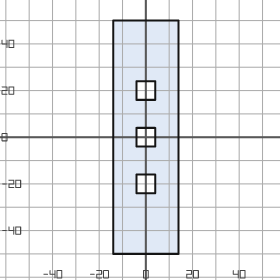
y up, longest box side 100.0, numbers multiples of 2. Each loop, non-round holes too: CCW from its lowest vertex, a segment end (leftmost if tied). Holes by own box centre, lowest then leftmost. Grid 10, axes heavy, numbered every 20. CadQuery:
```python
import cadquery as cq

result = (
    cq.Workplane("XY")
    .moveTo(-14.0, -50.0)
    .lineTo(14.0, -50.0)
    .lineTo(14.0, 50.0)
    .lineTo(-14.0, 50.0)
    .close()
    .moveTo(-4.0, -24.0)
    .lineTo(4.0, -24.0)
    .lineTo(4.0, -16.0)
    .lineTo(-4.0, -16.0)
    .close()
    .moveTo(-4.0, -4.0)
    .lineTo(4.0, -4.0)
    .lineTo(4.0, 4.0)
    .lineTo(-4.0, 4.0)
    .close()
    .moveTo(-4.0, 16.0)
    .lineTo(4.0, 16.0)
    .lineTo(4.0, 24.0)
    .lineTo(-4.0, 24.0)
    .close()
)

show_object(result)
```